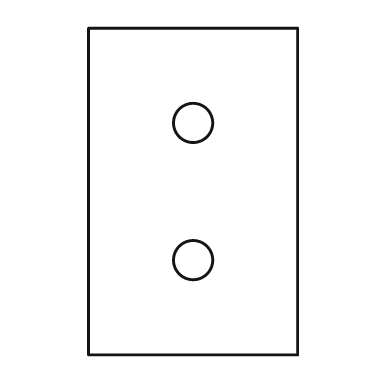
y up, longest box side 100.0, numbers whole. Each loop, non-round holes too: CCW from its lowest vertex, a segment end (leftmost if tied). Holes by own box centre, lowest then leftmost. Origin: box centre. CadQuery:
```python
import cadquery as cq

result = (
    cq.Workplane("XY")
    .moveTo(-32.0, -50.0)
    .lineTo(32.0, -50.0)
    .lineTo(32.0, 50.0)
    .lineTo(-32.0, 50.0)
    .close()
    .moveTo(0.0, -21.0)
    .circle(6.0)
    .moveTo(0.0, 21.0)
    .circle(6.0)
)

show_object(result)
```